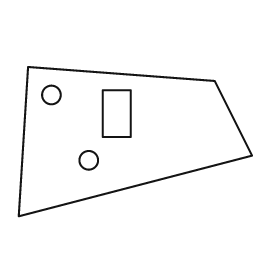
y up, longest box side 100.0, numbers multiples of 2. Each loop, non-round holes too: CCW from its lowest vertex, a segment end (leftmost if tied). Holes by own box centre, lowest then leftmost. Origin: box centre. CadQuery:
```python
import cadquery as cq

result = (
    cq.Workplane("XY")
    .moveTo(-50.0, -32.0)
    .lineTo(50.0, -6.0)
    .lineTo(34.0, 26.0)
    .lineTo(-46.0, 32.0)
    .close()
    .moveTo(-20.0, -8.0)
    .circle(4.0)
    .moveTo(-14.0, 2.0)
    .lineTo(-2.0, 2.0)
    .lineTo(-2.0, 22.0)
    .lineTo(-14.0, 22.0)
    .close()
    .moveTo(-36.0, 20.0)
    .circle(4.0)
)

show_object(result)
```